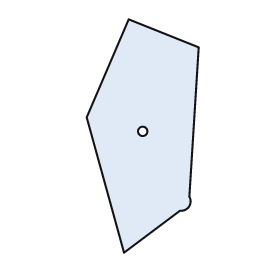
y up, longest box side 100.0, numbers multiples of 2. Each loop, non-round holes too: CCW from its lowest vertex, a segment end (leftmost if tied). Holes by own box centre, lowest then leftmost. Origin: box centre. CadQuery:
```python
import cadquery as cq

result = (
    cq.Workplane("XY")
    .moveTo(-8.0, -50.0)
    .lineTo(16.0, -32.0)
    .threePointArc((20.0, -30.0), (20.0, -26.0))
    .lineTo(24.0, 38.0)
    .lineTo(-6.0, 50.0)
    .lineTo(-24.0, 8.0)
    .close()
    .moveTo(0.0, 2.0)
    .circle(2.0)
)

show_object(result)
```